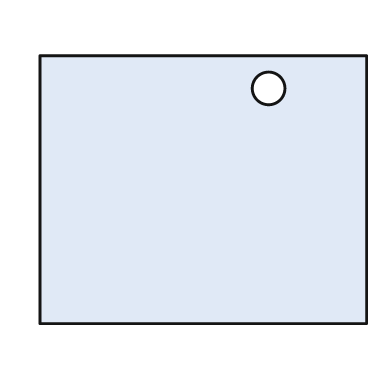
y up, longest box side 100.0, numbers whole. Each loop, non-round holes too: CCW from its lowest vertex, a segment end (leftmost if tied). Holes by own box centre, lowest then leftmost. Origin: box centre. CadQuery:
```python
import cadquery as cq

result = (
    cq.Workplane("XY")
    .moveTo(-50.0, -41.0)
    .lineTo(50.0, -41.0)
    .lineTo(50.0, 41.0)
    .lineTo(-50.0, 41.0)
    .close()
    .moveTo(20.0, 31.0)
    .circle(5.0)
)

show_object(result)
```